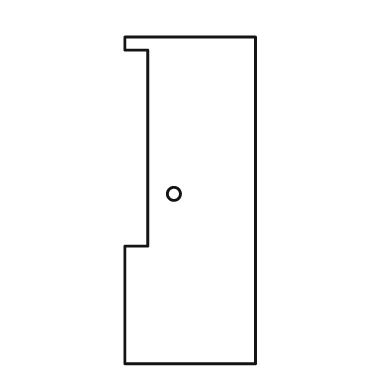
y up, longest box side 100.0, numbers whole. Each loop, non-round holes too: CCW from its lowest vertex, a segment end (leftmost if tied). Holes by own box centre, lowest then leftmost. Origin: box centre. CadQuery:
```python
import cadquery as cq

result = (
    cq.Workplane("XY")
    .moveTo(-20.0, -50.0)
    .lineTo(20.0, -50.0)
    .lineTo(20.0, 50.0)
    .lineTo(-20.0, 50.0)
    .lineTo(-20.0, 46.0)
    .lineTo(-13.0, 46.0)
    .lineTo(-13.0, -14.0)
    .lineTo(-20.0, -14.0)
    .close()
    .moveTo(-5.0, 2.0)
    .circle(2.0)
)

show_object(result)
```